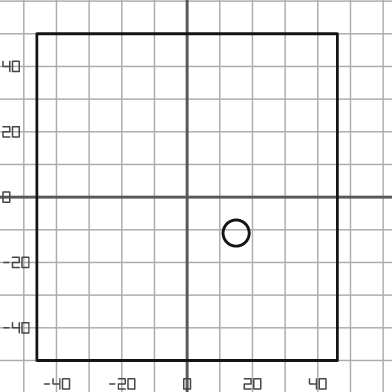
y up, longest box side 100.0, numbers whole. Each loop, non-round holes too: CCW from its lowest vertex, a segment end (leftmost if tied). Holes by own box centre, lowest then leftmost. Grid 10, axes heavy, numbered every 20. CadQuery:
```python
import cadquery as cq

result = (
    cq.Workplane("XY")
    .moveTo(-46.0, -50.0)
    .lineTo(46.0, -50.0)
    .lineTo(46.0, 50.0)
    .lineTo(-46.0, 50.0)
    .close()
    .moveTo(15.0, -11.0)
    .circle(4.0)
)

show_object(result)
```